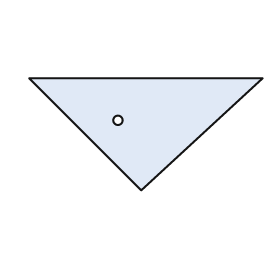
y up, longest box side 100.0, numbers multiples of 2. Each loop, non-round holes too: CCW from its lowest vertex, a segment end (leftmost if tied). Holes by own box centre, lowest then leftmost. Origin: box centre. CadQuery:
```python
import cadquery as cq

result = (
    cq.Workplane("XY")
    .moveTo(-2.0, -24.0)
    .lineTo(50.0, 24.0)
    .lineTo(-50.0, 24.0)
    .close()
    .moveTo(-12.0, 6.0)
    .circle(2.0)
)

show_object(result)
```